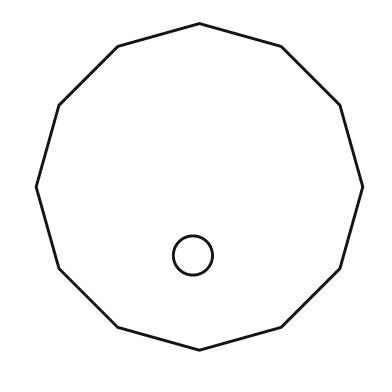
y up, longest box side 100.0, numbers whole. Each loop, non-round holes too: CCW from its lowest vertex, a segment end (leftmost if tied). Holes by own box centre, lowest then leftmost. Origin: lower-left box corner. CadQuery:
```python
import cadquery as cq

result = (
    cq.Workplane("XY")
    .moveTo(50.0, 0.0)
    .lineTo(75.0, 7.0)
    .lineTo(93.0, 25.0)
    .lineTo(100.0, 50.0)
    .lineTo(93.0, 75.0)
    .lineTo(75.0, 93.0)
    .lineTo(50.0, 100.0)
    .lineTo(25.0, 93.0)
    .lineTo(7.0, 75.0)
    .lineTo(0.0, 50.0)
    .lineTo(7.0, 25.0)
    .lineTo(25.0, 7.0)
    .close()
    .moveTo(48.0, 29.0)
    .circle(6.0)
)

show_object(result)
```